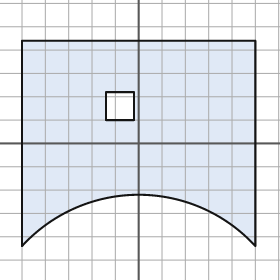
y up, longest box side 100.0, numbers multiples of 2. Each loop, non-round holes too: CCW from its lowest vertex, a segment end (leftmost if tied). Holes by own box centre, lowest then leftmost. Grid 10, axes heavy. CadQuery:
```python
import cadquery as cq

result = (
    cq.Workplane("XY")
    .moveTo(-50.0, -44.0)
    .threePointArc((0.0, -22.0), (50.0, -44.0))
    .lineTo(50.0, 44.0)
    .lineTo(-50.0, 44.0)
    .close()
    .moveTo(-14.0, 10.0)
    .lineTo(-2.0, 10.0)
    .lineTo(-2.0, 22.0)
    .lineTo(-14.0, 22.0)
    .close()
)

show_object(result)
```